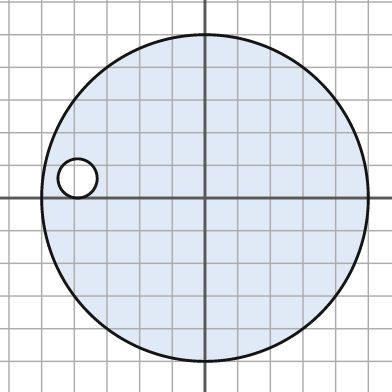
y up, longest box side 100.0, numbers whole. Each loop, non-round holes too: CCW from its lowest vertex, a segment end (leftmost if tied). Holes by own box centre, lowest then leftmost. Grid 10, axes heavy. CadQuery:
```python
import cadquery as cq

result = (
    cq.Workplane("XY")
    .moveTo(0.0, 0.0)
    .circle(50.0)
    .moveTo(-39.0, 6.0)
    .circle(6.0)
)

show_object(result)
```